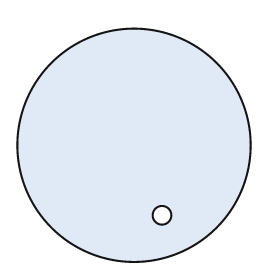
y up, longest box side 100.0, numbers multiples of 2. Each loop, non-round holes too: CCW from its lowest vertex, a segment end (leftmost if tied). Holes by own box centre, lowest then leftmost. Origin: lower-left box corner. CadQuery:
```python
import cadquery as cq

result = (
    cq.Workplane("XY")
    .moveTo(50.0, 50.0)
    .circle(50.0)
    .moveTo(62.0, 20.0)
    .circle(4.0)
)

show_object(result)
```